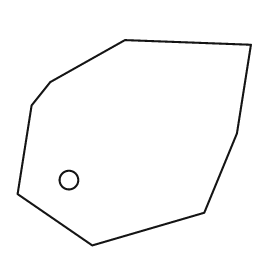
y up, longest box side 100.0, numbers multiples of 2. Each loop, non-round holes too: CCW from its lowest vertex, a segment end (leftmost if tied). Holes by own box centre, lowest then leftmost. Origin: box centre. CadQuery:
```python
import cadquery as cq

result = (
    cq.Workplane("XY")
    .moveTo(-18.0, -44.0)
    .lineTo(30.0, -30.0)
    .lineTo(44.0, 4.0)
    .lineTo(50.0, 42.0)
    .lineTo(-4.0, 44.0)
    .lineTo(-36.0, 26.0)
    .lineTo(-44.0, 16.0)
    .lineTo(-50.0, -22.0)
    .close()
    .moveTo(-28.0, -16.0)
    .circle(4.0)
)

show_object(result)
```